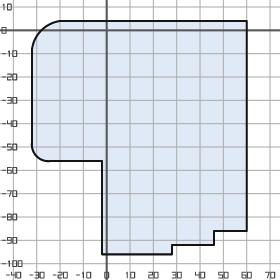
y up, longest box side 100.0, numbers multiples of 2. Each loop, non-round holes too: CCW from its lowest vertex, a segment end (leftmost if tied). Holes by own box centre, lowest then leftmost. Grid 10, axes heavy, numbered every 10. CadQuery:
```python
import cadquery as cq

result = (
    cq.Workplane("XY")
    .moveTo(-2.0, -96.0)
    .lineTo(28.0, -96.0)
    .lineTo(28.0, -92.0)
    .lineTo(46.0, -92.0)
    .lineTo(46.0, -86.0)
    .lineTo(60.0, -86.0)
    .lineTo(60.0, 4.0)
    .lineTo(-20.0, 4.0)
    .threePointArc((-28.0, 0.0), (-32.0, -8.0))
    .lineTo(-32.0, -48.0)
    .threePointArc((-30.0, -54.0), (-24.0, -56.0))
    .lineTo(-2.0, -56.0)
    .close()
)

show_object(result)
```